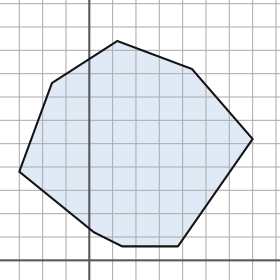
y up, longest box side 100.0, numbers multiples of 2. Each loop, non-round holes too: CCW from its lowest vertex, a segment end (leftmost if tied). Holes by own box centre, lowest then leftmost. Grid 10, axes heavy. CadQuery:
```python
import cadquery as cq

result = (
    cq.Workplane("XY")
    .moveTo(14.0, 6.0)
    .lineTo(38.0, 6.0)
    .lineTo(70.0, 52.0)
    .lineTo(44.0, 82.0)
    .lineTo(12.0, 94.0)
    .lineTo(-16.0, 76.0)
    .lineTo(-30.0, 38.0)
    .lineTo(2.0, 12.0)
    .close()
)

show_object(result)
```